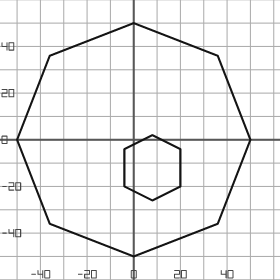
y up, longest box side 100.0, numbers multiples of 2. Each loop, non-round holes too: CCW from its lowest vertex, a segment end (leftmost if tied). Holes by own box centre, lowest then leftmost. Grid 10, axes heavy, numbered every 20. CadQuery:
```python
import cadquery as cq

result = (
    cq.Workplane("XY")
    .moveTo(0.0, -50.0)
    .lineTo(36.0, -36.0)
    .lineTo(50.0, 0.0)
    .lineTo(36.0, 36.0)
    .lineTo(0.0, 50.0)
    .lineTo(-36.0, 36.0)
    .lineTo(-50.0, 0.0)
    .lineTo(-36.0, -36.0)
    .close()
    .moveTo(8.0, -26.0)
    .lineTo(20.0, -20.0)
    .lineTo(20.0, -4.0)
    .lineTo(8.0, 2.0)
    .lineTo(-4.0, -4.0)
    .lineTo(-4.0, -20.0)
    .close()
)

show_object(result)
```